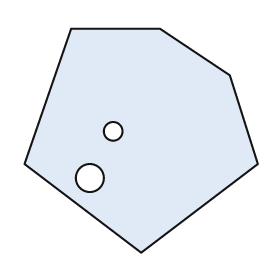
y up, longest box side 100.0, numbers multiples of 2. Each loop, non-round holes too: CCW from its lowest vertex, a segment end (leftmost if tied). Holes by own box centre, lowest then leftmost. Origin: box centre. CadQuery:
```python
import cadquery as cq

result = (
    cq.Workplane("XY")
    .moveTo(0.0, -48.0)
    .lineTo(50.0, -10.0)
    .lineTo(38.0, 28.0)
    .lineTo(8.0, 48.0)
    .lineTo(-30.0, 48.0)
    .lineTo(-50.0, -10.0)
    .close()
    .moveTo(-22.0, -16.0)
    .circle(6.0)
    .moveTo(-12.0, 4.0)
    .circle(4.0)
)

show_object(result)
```